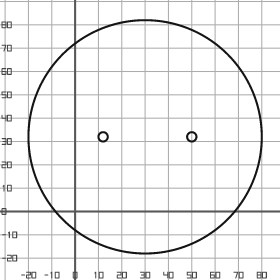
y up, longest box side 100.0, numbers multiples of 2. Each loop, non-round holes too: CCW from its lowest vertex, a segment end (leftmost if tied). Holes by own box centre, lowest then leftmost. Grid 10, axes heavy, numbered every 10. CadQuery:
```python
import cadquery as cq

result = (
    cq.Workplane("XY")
    .moveTo(30.0, 32.0)
    .circle(50.0)
    .moveTo(12.0, 32.0)
    .circle(2.0)
    .moveTo(50.0, 32.0)
    .circle(2.0)
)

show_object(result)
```